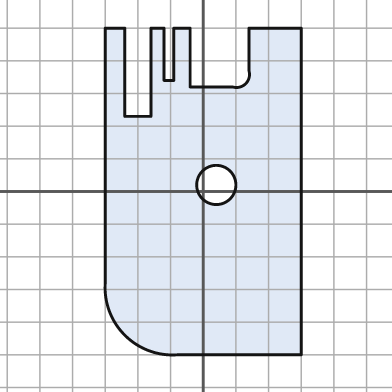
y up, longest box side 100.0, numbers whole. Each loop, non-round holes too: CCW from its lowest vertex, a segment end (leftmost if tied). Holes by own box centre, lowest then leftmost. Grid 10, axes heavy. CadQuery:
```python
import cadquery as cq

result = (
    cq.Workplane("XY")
    .moveTo(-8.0, -50.0)
    .lineTo(30.0, -50.0)
    .lineTo(30.0, 50.0)
    .lineTo(14.0, 50.0)
    .lineTo(14.0, 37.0)
    .threePointArc((13.0, 33.0), (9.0, 32.0))
    .lineTo(-4.0, 32.0)
    .lineTo(-4.0, 50.0)
    .lineTo(-9.0, 50.0)
    .lineTo(-9.0, 34.0)
    .lineTo(-12.0, 34.0)
    .lineTo(-12.0, 50.0)
    .lineTo(-16.0, 50.0)
    .lineTo(-16.0, 23.0)
    .lineTo(-24.0, 23.0)
    .lineTo(-24.0, 50.0)
    .lineTo(-30.0, 50.0)
    .lineTo(-30.0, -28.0)
    .threePointArc((-24.0, -44.0), (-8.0, -50.0))
    .close()
    .moveTo(4.0, 2.0)
    .circle(6.0)
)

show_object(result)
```